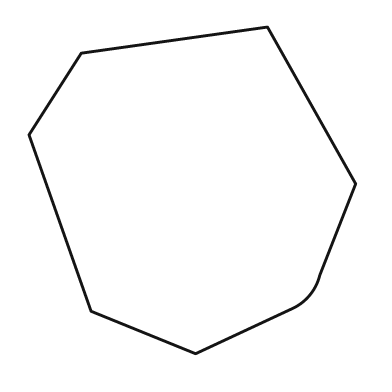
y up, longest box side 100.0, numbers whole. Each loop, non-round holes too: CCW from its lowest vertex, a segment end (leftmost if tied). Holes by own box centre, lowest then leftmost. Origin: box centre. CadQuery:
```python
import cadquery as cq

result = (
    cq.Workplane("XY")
    .moveTo(1.0, -50.0)
    .lineTo(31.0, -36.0)
    .threePointArc((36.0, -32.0), (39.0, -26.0))
    .lineTo(50.0, 2.0)
    .lineTo(23.0, 50.0)
    .lineTo(-34.0, 42.0)
    .lineTo(-50.0, 17.0)
    .lineTo(-31.0, -37.0)
    .close()
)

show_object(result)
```